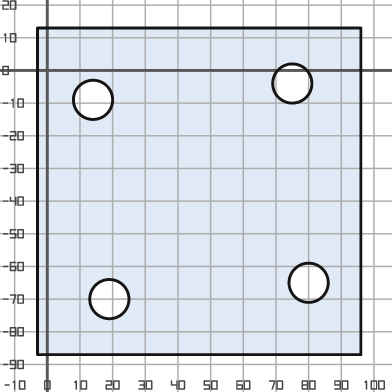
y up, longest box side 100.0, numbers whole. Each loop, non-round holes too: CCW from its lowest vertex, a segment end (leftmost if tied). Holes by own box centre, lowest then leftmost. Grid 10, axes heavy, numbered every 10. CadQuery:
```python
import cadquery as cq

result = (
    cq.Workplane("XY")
    .moveTo(-3.0, -87.0)
    .lineTo(96.0, -87.0)
    .lineTo(96.0, 13.0)
    .lineTo(-3.0, 13.0)
    .close()
    .moveTo(19.0, -70.0)
    .circle(6.0)
    .moveTo(80.0, -65.0)
    .circle(6.0)
    .moveTo(14.0, -9.0)
    .circle(6.0)
    .moveTo(75.0, -4.0)
    .circle(6.0)
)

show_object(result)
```